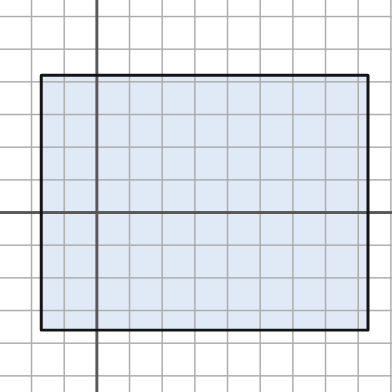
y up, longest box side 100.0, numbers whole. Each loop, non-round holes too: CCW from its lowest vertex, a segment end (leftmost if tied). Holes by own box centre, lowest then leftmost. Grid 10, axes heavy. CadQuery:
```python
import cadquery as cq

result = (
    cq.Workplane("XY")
    .moveTo(-17.0, -36.0)
    .lineTo(83.0, -36.0)
    .lineTo(83.0, 42.0)
    .lineTo(-17.0, 42.0)
    .close()
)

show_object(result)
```